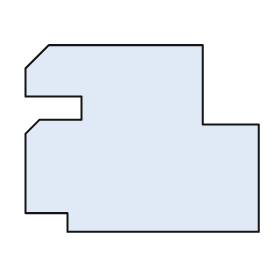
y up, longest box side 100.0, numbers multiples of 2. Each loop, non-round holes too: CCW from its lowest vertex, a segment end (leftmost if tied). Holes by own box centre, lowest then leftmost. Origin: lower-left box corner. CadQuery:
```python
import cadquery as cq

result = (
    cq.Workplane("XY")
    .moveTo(18.0, 0.0)
    .lineTo(100.0, 0.0)
    .lineTo(100.0, 46.0)
    .lineTo(76.0, 46.0)
    .lineTo(76.0, 80.0)
    .lineTo(10.0, 80.0)
    .lineTo(0.0, 70.0)
    .lineTo(0.0, 58.0)
    .lineTo(24.0, 58.0)
    .lineTo(24.0, 48.0)
    .lineTo(6.0, 48.0)
    .lineTo(0.0, 42.0)
    .lineTo(0.0, 8.0)
    .lineTo(18.0, 8.0)
    .close()
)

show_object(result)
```